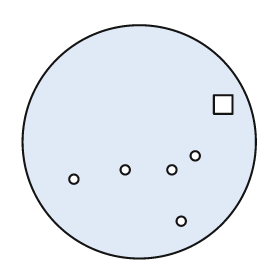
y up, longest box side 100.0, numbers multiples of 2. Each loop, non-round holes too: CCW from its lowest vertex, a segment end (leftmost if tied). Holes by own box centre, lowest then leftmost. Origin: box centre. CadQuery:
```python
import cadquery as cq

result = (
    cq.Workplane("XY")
    .moveTo(0.0, 0.0)
    .circle(50.0)
    .moveTo(18.0, -34.0)
    .circle(2.0)
    .moveTo(-28.0, -16.0)
    .circle(2.0)
    .moveTo(-6.0, -12.0)
    .circle(2.0)
    .moveTo(14.0, -12.0)
    .circle(2.0)
    .moveTo(24.0, -6.0)
    .circle(2.0)
    .moveTo(32.0, 12.0)
    .lineTo(40.0, 12.0)
    .lineTo(40.0, 20.0)
    .lineTo(32.0, 20.0)
    .close()
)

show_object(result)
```